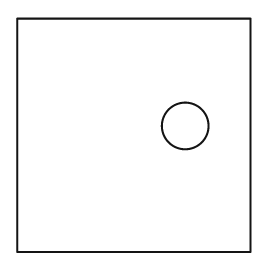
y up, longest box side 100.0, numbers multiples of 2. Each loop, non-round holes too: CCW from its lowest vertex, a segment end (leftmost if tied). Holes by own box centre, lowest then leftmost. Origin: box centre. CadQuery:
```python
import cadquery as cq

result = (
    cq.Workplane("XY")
    .moveTo(-50.0, -50.0)
    .lineTo(50.0, -50.0)
    .lineTo(50.0, 50.0)
    .lineTo(-50.0, 50.0)
    .close()
    .moveTo(22.0, 4.0)
    .circle(10.0)
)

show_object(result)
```